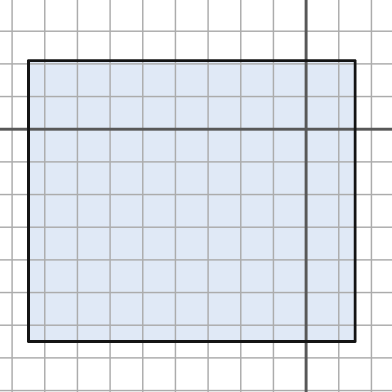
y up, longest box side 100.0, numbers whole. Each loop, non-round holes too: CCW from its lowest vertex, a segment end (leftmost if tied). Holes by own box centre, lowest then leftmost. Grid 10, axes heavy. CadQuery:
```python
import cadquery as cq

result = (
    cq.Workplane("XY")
    .moveTo(-85.0, -65.0)
    .lineTo(15.0, -65.0)
    .lineTo(15.0, 21.0)
    .lineTo(-85.0, 21.0)
    .close()
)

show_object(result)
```